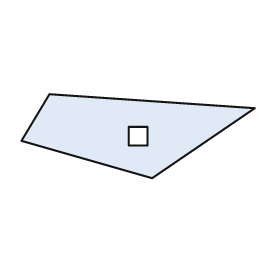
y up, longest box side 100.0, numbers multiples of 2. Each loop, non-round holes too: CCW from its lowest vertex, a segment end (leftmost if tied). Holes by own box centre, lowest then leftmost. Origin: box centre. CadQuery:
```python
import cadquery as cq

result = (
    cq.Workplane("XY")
    .moveTo(6.0, -18.0)
    .lineTo(50.0, 12.0)
    .lineTo(-38.0, 18.0)
    .lineTo(-50.0, -2.0)
    .close()
    .moveTo(-4.0, -4.0)
    .lineTo(4.0, -4.0)
    .lineTo(4.0, 4.0)
    .lineTo(-4.0, 4.0)
    .close()
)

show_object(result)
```